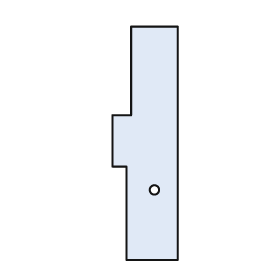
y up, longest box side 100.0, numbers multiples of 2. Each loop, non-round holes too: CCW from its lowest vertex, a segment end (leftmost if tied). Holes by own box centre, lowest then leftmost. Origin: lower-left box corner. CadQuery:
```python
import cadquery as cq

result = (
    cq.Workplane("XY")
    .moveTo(6.0, 0.0)
    .lineTo(28.0, 0.0)
    .lineTo(28.0, 100.0)
    .lineTo(8.0, 100.0)
    .lineTo(8.0, 62.0)
    .lineTo(0.0, 62.0)
    .lineTo(0.0, 40.0)
    .lineTo(6.0, 40.0)
    .close()
    .moveTo(18.0, 30.0)
    .circle(2.0)
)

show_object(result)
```